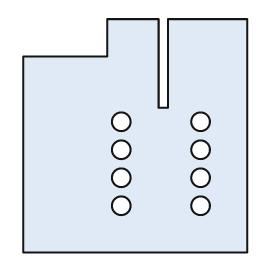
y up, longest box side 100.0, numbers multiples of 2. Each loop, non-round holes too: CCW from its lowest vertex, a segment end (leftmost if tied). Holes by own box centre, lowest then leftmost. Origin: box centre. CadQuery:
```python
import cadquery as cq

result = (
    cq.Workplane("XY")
    .moveTo(-48.0, -50.0)
    .lineTo(48.0, -50.0)
    .lineTo(48.0, 50.0)
    .lineTo(14.0, 50.0)
    .lineTo(14.0, 12.0)
    .lineTo(10.0, 12.0)
    .lineTo(10.0, 50.0)
    .lineTo(-12.0, 50.0)
    .lineTo(-12.0, 34.0)
    .lineTo(-48.0, 34.0)
    .close()
    .moveTo(-6.0, -30.0)
    .circle(4.0)
    .moveTo(28.0, -30.0)
    .circle(4.0)
    .moveTo(-6.0, -18.0)
    .circle(4.0)
    .moveTo(28.0, -18.0)
    .circle(4.0)
    .moveTo(-6.0, -6.0)
    .circle(4.0)
    .moveTo(28.0, -6.0)
    .circle(4.0)
    .moveTo(-6.0, 6.0)
    .circle(4.0)
    .moveTo(28.0, 6.0)
    .circle(4.0)
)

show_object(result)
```